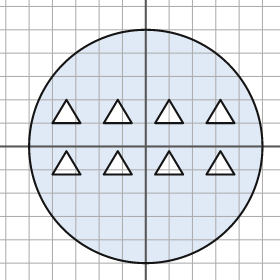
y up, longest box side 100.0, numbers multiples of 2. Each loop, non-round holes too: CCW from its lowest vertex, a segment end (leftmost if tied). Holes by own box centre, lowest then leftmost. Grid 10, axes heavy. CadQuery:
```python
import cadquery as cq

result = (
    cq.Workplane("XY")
    .moveTo(0.0, 0.0)
    .circle(50.0)
    .moveTo(-40.0, -12.0)
    .lineTo(-28.0, -12.0)
    .lineTo(-34.0, -2.0)
    .close()
    .moveTo(-18.0, -12.0)
    .lineTo(-6.0, -12.0)
    .lineTo(-12.0, -2.0)
    .close()
    .moveTo(4.0, -12.0)
    .lineTo(16.0, -12.0)
    .lineTo(10.0, -2.0)
    .close()
    .moveTo(26.0, -12.0)
    .lineTo(38.0, -12.0)
    .lineTo(32.0, -2.0)
    .close()
    .moveTo(-40.0, 10.0)
    .lineTo(-28.0, 10.0)
    .lineTo(-34.0, 20.0)
    .close()
    .moveTo(-18.0, 10.0)
    .lineTo(-6.0, 10.0)
    .lineTo(-12.0, 20.0)
    .close()
    .moveTo(4.0, 10.0)
    .lineTo(16.0, 10.0)
    .lineTo(10.0, 20.0)
    .close()
    .moveTo(26.0, 10.0)
    .lineTo(38.0, 10.0)
    .lineTo(32.0, 20.0)
    .close()
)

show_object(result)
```